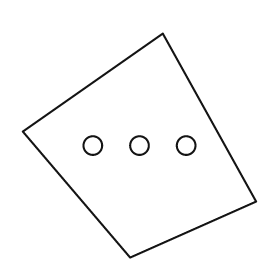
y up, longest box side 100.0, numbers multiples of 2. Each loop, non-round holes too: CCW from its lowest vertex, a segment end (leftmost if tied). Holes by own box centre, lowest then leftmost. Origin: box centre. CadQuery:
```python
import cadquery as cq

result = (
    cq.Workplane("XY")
    .moveTo(-4.0, -48.0)
    .lineTo(50.0, -24.0)
    .lineTo(10.0, 48.0)
    .lineTo(-50.0, 6.0)
    .close()
    .moveTo(-20.0, 0.0)
    .circle(4.0)
    .moveTo(0.0, 0.0)
    .circle(4.0)
    .moveTo(20.0, 0.0)
    .circle(4.0)
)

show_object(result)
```